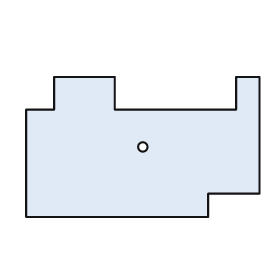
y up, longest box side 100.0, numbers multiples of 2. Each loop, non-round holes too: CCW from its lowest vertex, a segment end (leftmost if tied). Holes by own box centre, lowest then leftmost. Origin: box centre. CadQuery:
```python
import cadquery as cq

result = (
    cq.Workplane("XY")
    .moveTo(-50.0, -30.0)
    .lineTo(28.0, -30.0)
    .lineTo(28.0, -20.0)
    .lineTo(50.0, -20.0)
    .lineTo(50.0, 30.0)
    .lineTo(40.0, 30.0)
    .lineTo(40.0, 16.0)
    .lineTo(-12.0, 16.0)
    .lineTo(-12.0, 30.0)
    .lineTo(-38.0, 30.0)
    .lineTo(-38.0, 16.0)
    .lineTo(-50.0, 16.0)
    .close()
    .moveTo(0.0, 0.0)
    .circle(2.0)
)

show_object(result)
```